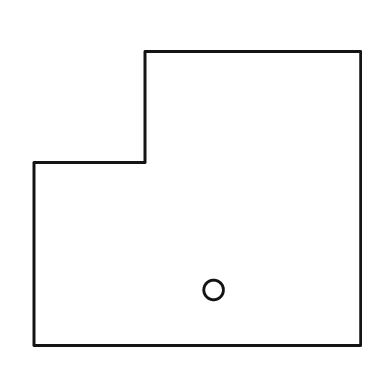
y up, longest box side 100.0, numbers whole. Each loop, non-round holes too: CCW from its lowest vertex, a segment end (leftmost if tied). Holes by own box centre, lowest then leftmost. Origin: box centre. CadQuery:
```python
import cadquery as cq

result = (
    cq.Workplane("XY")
    .moveTo(-50.0, -45.0)
    .lineTo(50.0, -45.0)
    .lineTo(50.0, 45.0)
    .lineTo(-16.0, 45.0)
    .lineTo(-16.0, 11.0)
    .lineTo(-50.0, 11.0)
    .close()
    .moveTo(5.0, -28.0)
    .circle(3.0)
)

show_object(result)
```